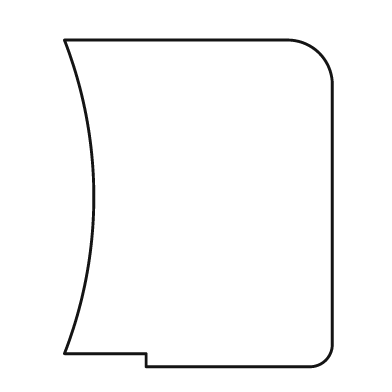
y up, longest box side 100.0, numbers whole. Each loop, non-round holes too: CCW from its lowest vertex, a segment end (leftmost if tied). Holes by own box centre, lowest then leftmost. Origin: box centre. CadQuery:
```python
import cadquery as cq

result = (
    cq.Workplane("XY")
    .moveTo(-16.0, -50.0)
    .lineTo(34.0, -50.0)
    .threePointArc((39.0, -48.0), (41.0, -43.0))
    .lineTo(41.0, 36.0)
    .threePointArc((37.0, 46.0), (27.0, 50.0))
    .lineTo(-41.0, 50.0)
    .threePointArc((-32.0, 2.0), (-41.0, -46.0))
    .lineTo(-16.0, -46.0)
    .close()
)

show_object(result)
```